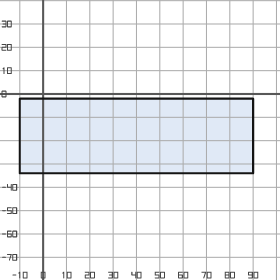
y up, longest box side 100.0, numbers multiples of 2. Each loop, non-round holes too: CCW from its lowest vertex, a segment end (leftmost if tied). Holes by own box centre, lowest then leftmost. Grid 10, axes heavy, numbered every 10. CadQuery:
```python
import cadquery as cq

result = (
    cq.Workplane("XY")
    .moveTo(-10.0, -34.0)
    .lineTo(90.0, -34.0)
    .lineTo(90.0, -2.0)
    .lineTo(-10.0, -2.0)
    .close()
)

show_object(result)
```